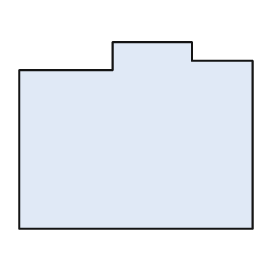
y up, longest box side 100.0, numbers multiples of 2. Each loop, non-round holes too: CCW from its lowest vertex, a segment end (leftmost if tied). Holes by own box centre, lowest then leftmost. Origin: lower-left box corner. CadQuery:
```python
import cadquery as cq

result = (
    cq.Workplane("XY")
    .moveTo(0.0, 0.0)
    .lineTo(100.0, 0.0)
    .lineTo(100.0, 72.0)
    .lineTo(74.0, 72.0)
    .lineTo(74.0, 80.0)
    .lineTo(40.0, 80.0)
    .lineTo(40.0, 68.0)
    .lineTo(0.0, 68.0)
    .close()
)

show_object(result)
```